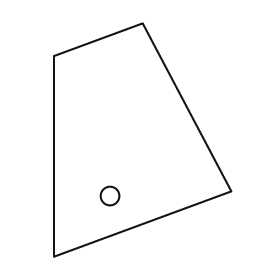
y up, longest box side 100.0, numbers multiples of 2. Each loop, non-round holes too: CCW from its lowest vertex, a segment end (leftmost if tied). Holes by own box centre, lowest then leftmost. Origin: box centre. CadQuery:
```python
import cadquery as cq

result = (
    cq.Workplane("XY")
    .moveTo(-38.0, -50.0)
    .lineTo(38.0, -22.0)
    .lineTo(0.0, 50.0)
    .lineTo(-38.0, 36.0)
    .close()
    .moveTo(-14.0, -24.0)
    .circle(4.0)
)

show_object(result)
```